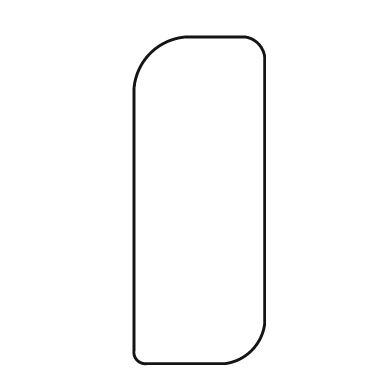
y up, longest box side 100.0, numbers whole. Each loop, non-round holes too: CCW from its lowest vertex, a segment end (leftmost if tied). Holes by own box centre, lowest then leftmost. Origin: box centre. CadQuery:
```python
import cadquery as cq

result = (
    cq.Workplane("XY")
    .moveTo(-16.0, -50.0)
    .lineTo(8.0, -50.0)
    .threePointArc((16.0, -46.0), (20.0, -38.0))
    .lineTo(20.0, 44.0)
    .threePointArc((18.0, 48.0), (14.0, 50.0))
    .lineTo(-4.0, 50.0)
    .threePointArc((-15.0, 45.0), (-20.0, 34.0))
    .lineTo(-20.0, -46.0)
    .threePointArc((-19.0, -49.0), (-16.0, -50.0))
    .close()
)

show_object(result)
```